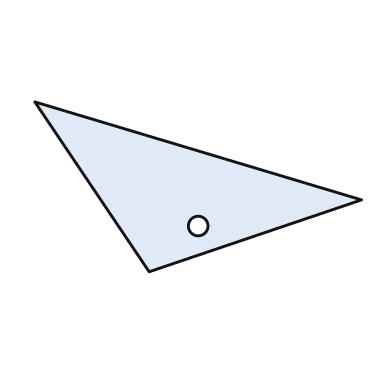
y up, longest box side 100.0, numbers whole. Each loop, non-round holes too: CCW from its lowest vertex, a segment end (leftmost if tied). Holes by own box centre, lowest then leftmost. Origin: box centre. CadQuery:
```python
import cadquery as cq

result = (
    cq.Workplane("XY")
    .moveTo(-15.0, -26.0)
    .lineTo(50.0, -4.0)
    .lineTo(-50.0, 26.0)
    .close()
    .moveTo(0.0, -12.0)
    .circle(3.0)
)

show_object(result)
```